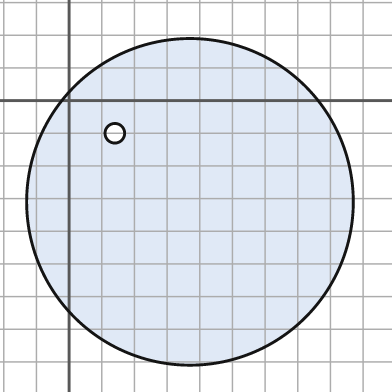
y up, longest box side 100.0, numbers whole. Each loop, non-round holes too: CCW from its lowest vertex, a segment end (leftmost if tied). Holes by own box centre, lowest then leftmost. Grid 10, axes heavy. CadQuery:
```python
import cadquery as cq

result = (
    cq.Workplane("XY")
    .moveTo(37.0, -31.0)
    .circle(50.0)
    .moveTo(14.0, -10.0)
    .circle(3.0)
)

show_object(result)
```